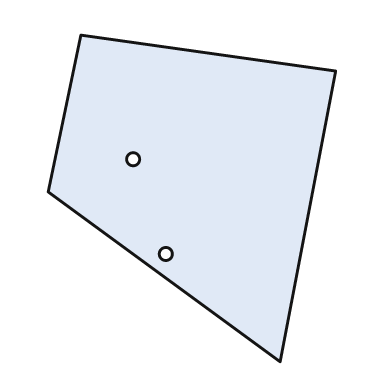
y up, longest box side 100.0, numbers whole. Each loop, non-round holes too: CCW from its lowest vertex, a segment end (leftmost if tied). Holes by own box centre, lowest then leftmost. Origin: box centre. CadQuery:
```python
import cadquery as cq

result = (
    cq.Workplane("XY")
    .moveTo(27.0, -50.0)
    .lineTo(44.0, 39.0)
    .lineTo(-34.0, 50.0)
    .lineTo(-44.0, 2.0)
    .close()
    .moveTo(-8.0, -17.0)
    .circle(2.0)
    .moveTo(-18.0, 12.0)
    .circle(2.0)
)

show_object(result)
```